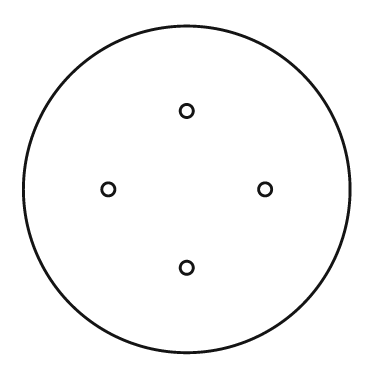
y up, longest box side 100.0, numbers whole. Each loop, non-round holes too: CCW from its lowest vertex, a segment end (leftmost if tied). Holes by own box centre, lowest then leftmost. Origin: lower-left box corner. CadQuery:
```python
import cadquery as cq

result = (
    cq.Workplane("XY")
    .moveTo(50.0, 50.0)
    .circle(50.0)
    .moveTo(50.0, 26.0)
    .circle(2.0)
    .moveTo(26.0, 50.0)
    .circle(2.0)
    .moveTo(74.0, 50.0)
    .circle(2.0)
    .moveTo(50.0, 74.0)
    .circle(2.0)
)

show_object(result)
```